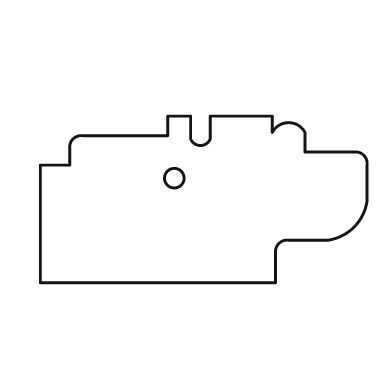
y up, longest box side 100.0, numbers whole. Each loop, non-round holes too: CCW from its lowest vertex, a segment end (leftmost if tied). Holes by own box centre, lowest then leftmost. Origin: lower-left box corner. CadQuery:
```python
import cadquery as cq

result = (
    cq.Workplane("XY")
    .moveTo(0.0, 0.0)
    .lineTo(72.0, 0.0)
    .lineTo(72.0, 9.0)
    .threePointArc((73.0, 12.0), (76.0, 13.0))
    .lineTo(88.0, 13.0)
    .threePointArc((96.0, 17.0), (100.0, 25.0))
    .lineTo(100.0, 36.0)
    .threePointArc((99.0, 39.0), (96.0, 40.0))
    .lineTo(81.0, 40.0)
    .lineTo(81.0, 46.0)
    .threePointArc((76.0, 49.0), (71.0, 46.0))
    .lineTo(71.0, 51.0)
    .lineTo(52.0, 51.0)
    .lineTo(52.0, 44.0)
    .threePointArc((49.0, 42.0), (46.0, 44.0))
    .lineTo(46.0, 51.0)
    .lineTo(39.0, 51.0)
    .lineTo(39.0, 45.0)
    .lineTo(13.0, 45.0)
    .threePointArc((10.0, 44.0), (9.0, 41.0))
    .lineTo(9.0, 36.0)
    .lineTo(0.0, 36.0)
    .close()
    .moveTo(41.0, 32.0)
    .circle(3.0)
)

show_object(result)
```